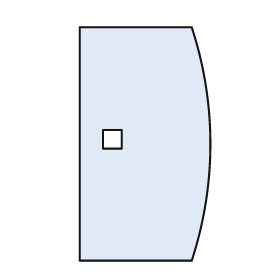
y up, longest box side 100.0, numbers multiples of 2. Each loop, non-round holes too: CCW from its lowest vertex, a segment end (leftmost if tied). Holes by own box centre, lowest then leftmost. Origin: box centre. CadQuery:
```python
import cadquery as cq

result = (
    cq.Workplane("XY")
    .moveTo(-28.0, -50.0)
    .lineTo(20.0, -50.0)
    .threePointArc((28.0, 0.0), (20.0, 50.0))
    .lineTo(-28.0, 50.0)
    .close()
    .moveTo(-18.0, -2.0)
    .lineTo(-10.0, -2.0)
    .lineTo(-10.0, 6.0)
    .lineTo(-18.0, 6.0)
    .close()
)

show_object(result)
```